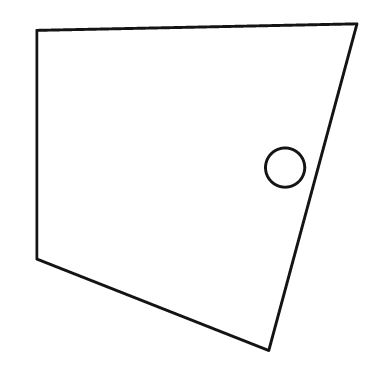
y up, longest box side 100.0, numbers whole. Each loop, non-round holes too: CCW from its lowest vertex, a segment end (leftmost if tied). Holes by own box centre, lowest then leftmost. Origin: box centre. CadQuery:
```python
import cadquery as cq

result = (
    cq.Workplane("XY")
    .moveTo(22.0, -50.0)
    .lineTo(49.0, 50.0)
    .lineTo(-49.0, 48.0)
    .lineTo(-49.0, -22.0)
    .close()
    .moveTo(27.0, 6.0)
    .circle(6.0)
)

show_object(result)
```